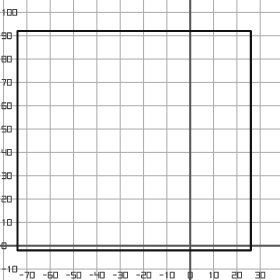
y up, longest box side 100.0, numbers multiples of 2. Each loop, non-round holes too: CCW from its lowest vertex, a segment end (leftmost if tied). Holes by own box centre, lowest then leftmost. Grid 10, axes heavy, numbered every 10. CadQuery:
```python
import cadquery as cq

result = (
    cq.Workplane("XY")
    .moveTo(-74.0, -2.0)
    .lineTo(26.0, -2.0)
    .lineTo(26.0, 92.0)
    .lineTo(-74.0, 92.0)
    .close()
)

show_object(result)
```